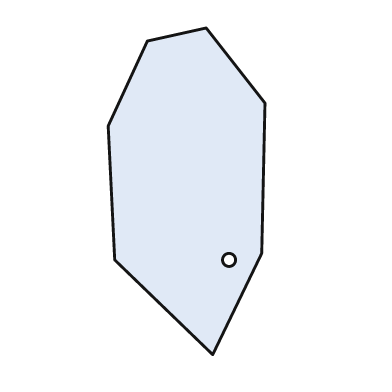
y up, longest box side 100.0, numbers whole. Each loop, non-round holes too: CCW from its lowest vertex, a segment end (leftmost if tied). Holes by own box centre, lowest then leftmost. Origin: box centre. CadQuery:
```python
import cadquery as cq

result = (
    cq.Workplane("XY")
    .moveTo(8.0, -50.0)
    .lineTo(23.0, -19.0)
    .lineTo(24.0, 27.0)
    .lineTo(6.0, 50.0)
    .lineTo(-12.0, 46.0)
    .lineTo(-24.0, 20.0)
    .lineTo(-22.0, -21.0)
    .close()
    .moveTo(13.0, -21.0)
    .circle(2.0)
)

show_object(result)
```